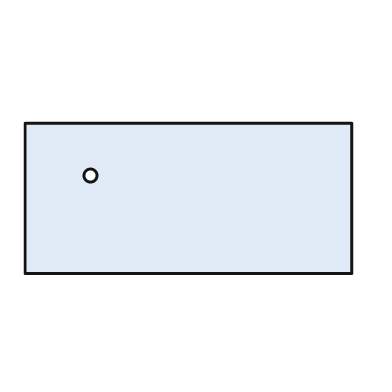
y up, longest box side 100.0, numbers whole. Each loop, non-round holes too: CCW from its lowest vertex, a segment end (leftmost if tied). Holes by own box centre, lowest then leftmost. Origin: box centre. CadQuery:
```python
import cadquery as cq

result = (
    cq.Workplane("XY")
    .moveTo(-50.0, -23.0)
    .lineTo(50.0, -23.0)
    .lineTo(50.0, 23.0)
    .lineTo(-50.0, 23.0)
    .close()
    .moveTo(-30.0, 7.0)
    .circle(2.0)
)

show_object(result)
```